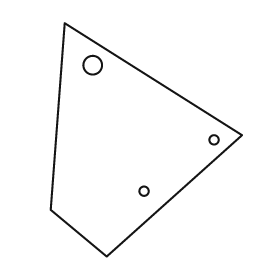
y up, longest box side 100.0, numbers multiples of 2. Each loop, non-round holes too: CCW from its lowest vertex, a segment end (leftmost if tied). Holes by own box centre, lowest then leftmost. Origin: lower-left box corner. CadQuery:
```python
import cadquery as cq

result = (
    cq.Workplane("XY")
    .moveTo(24.0, 0.0)
    .lineTo(82.0, 52.0)
    .lineTo(6.0, 100.0)
    .lineTo(0.0, 20.0)
    .close()
    .moveTo(40.0, 28.0)
    .circle(2.0)
    .moveTo(70.0, 50.0)
    .circle(2.0)
    .moveTo(18.0, 82.0)
    .circle(4.0)
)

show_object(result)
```